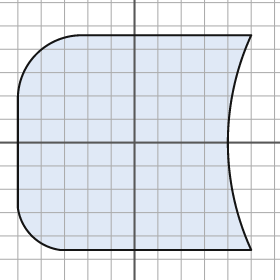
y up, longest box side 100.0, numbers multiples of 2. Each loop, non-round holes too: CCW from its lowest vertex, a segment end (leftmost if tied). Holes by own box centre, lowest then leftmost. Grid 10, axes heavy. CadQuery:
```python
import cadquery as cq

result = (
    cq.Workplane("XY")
    .moveTo(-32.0, -46.0)
    .lineTo(50.0, -46.0)
    .threePointArc((40.0, 0.0), (50.0, 46.0))
    .lineTo(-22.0, 46.0)
    .threePointArc((-42.0, 38.0), (-50.0, 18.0))
    .lineTo(-50.0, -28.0)
    .threePointArc((-44.0, -40.0), (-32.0, -46.0))
    .close()
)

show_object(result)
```